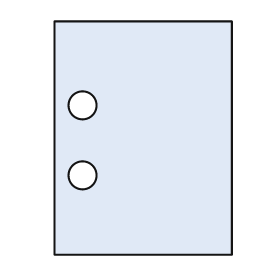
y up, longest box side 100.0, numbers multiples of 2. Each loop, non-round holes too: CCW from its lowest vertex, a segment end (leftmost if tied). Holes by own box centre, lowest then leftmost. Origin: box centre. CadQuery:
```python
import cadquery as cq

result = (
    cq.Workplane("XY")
    .moveTo(-38.0, -50.0)
    .lineTo(38.0, -50.0)
    .lineTo(38.0, 50.0)
    .lineTo(-38.0, 50.0)
    .close()
    .moveTo(-26.0, -16.0)
    .circle(6.0)
    .moveTo(-26.0, 14.0)
    .circle(6.0)
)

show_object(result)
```